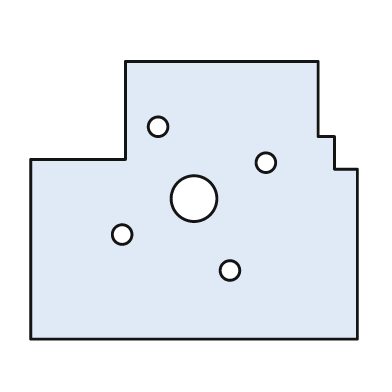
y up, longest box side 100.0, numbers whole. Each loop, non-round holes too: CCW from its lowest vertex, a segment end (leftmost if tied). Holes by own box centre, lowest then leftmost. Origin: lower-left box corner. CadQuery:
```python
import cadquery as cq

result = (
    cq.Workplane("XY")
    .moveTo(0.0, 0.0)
    .lineTo(100.0, 0.0)
    .lineTo(100.0, 52.0)
    .lineTo(93.0, 52.0)
    .lineTo(93.0, 62.0)
    .lineTo(88.0, 62.0)
    .lineTo(88.0, 85.0)
    .lineTo(29.0, 85.0)
    .lineTo(29.0, 55.0)
    .lineTo(0.0, 55.0)
    .close()
    .moveTo(61.0, 21.0)
    .circle(3.0)
    .moveTo(28.0, 32.0)
    .circle(3.0)
    .moveTo(50.0, 43.0)
    .circle(7.0)
    .moveTo(72.0, 54.0)
    .circle(3.0)
    .moveTo(39.0, 65.0)
    .circle(3.0)
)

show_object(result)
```